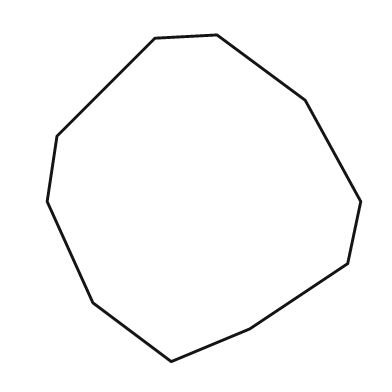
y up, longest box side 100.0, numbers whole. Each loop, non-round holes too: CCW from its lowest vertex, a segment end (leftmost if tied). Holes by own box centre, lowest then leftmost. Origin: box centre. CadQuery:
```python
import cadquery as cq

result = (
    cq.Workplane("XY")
    .moveTo(-10.0, -50.0)
    .lineTo(14.0, -40.0)
    .lineTo(44.0, -20.0)
    .lineTo(48.0, -1.0)
    .lineTo(31.0, 30.0)
    .lineTo(4.0, 50.0)
    .lineTo(-15.0, 49.0)
    .lineTo(-45.0, 19.0)
    .lineTo(-48.0, -1.0)
    .lineTo(-34.0, -32.0)
    .close()
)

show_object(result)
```